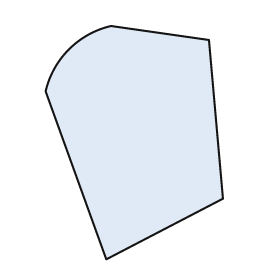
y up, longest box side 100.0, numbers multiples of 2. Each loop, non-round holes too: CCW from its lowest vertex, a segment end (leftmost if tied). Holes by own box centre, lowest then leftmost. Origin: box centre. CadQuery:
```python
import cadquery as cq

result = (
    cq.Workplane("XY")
    .moveTo(-12.0, -50.0)
    .lineTo(38.0, -24.0)
    .lineTo(32.0, 44.0)
    .lineTo(-10.0, 50.0)
    .threePointArc((-28.0, 40.0), (-38.0, 22.0))
    .close()
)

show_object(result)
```